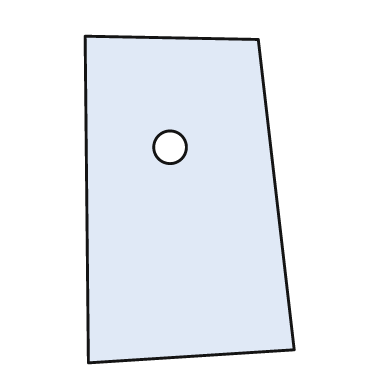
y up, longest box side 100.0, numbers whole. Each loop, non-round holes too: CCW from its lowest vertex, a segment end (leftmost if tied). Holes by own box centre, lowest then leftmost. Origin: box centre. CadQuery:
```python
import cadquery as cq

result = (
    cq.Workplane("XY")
    .moveTo(-31.0, -50.0)
    .lineTo(32.0, -46.0)
    .lineTo(21.0, 49.0)
    .lineTo(-32.0, 50.0)
    .close()
    .moveTo(-6.0, 16.0)
    .circle(5.0)
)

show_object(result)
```